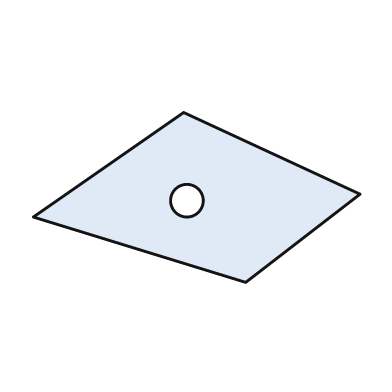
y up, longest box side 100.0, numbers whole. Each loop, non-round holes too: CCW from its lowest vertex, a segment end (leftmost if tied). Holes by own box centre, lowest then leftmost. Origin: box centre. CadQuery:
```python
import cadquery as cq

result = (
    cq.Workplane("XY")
    .moveTo(15.0, -26.0)
    .lineTo(50.0, 1.0)
    .lineTo(-4.0, 26.0)
    .lineTo(-50.0, -6.0)
    .close()
    .moveTo(-3.0, -1.0)
    .circle(5.0)
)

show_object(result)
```